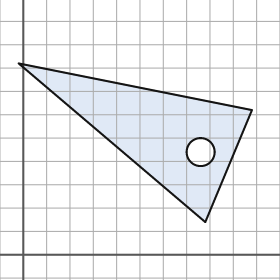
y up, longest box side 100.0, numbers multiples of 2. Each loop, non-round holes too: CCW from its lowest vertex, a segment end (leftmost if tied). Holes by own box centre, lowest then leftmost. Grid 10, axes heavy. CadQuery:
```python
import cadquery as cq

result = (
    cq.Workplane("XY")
    .moveTo(78.0, 14.0)
    .lineTo(98.0, 62.0)
    .lineTo(-2.0, 82.0)
    .close()
    .moveTo(76.0, 44.0)
    .circle(6.0)
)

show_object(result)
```